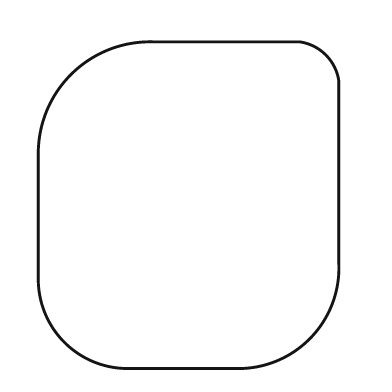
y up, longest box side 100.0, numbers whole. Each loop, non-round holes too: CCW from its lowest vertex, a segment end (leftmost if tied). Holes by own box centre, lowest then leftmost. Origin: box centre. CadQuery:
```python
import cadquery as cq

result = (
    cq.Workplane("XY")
    .moveTo(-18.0, -50.0)
    .lineTo(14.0, -50.0)
    .threePointArc((37.0, -41.0), (46.0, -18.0))
    .lineTo(46.0, 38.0)
    .threePointArc((42.0, 46.0), (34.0, 50.0))
    .lineTo(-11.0, 50.0)
    .threePointArc((-36.0, 40.0), (-46.0, 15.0))
    .lineTo(-46.0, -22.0)
    .threePointArc((-38.0, -42.0), (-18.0, -50.0))
    .close()
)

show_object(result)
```